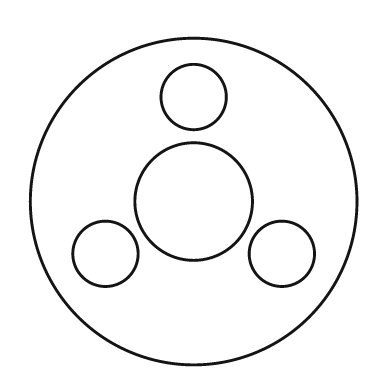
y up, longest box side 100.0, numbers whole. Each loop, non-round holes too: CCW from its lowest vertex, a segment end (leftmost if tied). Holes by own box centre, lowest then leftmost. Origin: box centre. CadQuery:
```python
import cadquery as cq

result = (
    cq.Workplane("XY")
    .moveTo(0.0, 0.0)
    .circle(50.0)
    .moveTo(-27.0, -16.0)
    .circle(10.0)
    .moveTo(27.0, -16.0)
    .circle(10.0)
    .moveTo(0.0, 0.0)
    .circle(18.0)
    .moveTo(0.0, 32.0)
    .circle(10.0)
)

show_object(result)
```